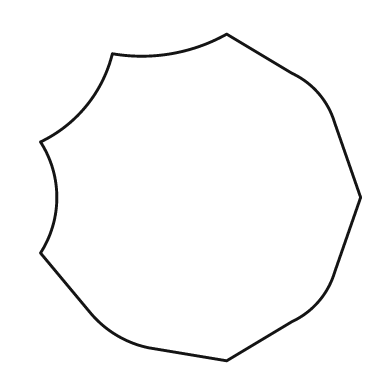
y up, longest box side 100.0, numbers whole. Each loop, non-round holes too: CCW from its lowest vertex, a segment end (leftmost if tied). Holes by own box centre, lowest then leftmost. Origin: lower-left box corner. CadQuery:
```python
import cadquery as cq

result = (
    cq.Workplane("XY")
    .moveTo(57.0, 0.0)
    .lineTo(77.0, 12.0)
    .threePointArc((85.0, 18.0), (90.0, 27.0))
    .lineTo(98.0, 50.0)
    .lineTo(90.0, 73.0)
    .threePointArc((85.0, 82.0), (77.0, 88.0))
    .lineTo(57.0, 100.0)
    .threePointArc((40.0, 94.0), (22.0, 94.0))
    .threePointArc((14.0, 78.0), (0.0, 67.0))
    .threePointArc((5.0, 50.0), (0.0, 33.0))
    .lineTo(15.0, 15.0)
    .threePointArc((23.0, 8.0), (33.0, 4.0))
    .close()
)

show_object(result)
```